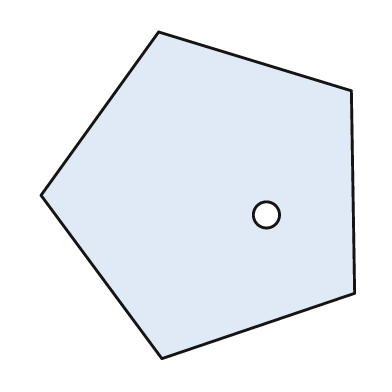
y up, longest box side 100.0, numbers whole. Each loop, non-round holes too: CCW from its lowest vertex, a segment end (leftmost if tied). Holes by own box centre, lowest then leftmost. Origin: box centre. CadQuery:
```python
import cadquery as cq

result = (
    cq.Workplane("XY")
    .moveTo(-11.0, -50.0)
    .lineTo(48.0, -30.0)
    .lineTo(47.0, 32.0)
    .lineTo(-12.0, 50.0)
    .lineTo(-48.0, 0.0)
    .close()
    .moveTo(21.0, -6.0)
    .circle(4.0)
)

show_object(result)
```